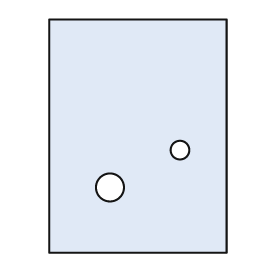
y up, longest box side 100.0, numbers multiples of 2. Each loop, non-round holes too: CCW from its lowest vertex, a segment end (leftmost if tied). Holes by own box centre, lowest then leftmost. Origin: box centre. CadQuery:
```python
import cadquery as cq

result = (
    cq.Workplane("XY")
    .moveTo(-38.0, -50.0)
    .lineTo(38.0, -50.0)
    .lineTo(38.0, 50.0)
    .lineTo(-38.0, 50.0)
    .close()
    .moveTo(-12.0, -22.0)
    .circle(6.0)
    .moveTo(18.0, -6.0)
    .circle(4.0)
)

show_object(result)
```